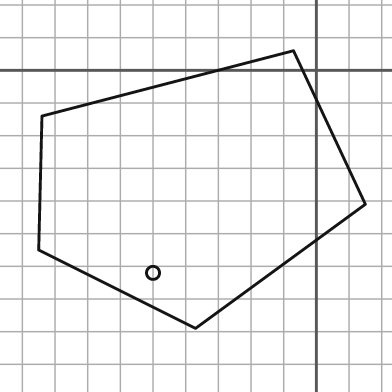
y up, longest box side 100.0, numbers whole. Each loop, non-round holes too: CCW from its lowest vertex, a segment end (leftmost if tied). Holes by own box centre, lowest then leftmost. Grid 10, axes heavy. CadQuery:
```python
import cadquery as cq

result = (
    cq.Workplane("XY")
    .moveTo(-37.0, -79.0)
    .lineTo(15.0, -41.0)
    .lineTo(-7.0, 6.0)
    .lineTo(-84.0, -14.0)
    .lineTo(-85.0, -55.0)
    .close()
    .moveTo(-50.0, -62.0)
    .circle(2.0)
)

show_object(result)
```